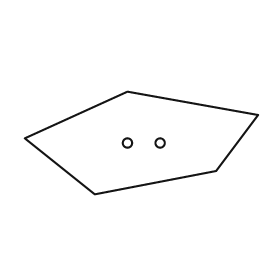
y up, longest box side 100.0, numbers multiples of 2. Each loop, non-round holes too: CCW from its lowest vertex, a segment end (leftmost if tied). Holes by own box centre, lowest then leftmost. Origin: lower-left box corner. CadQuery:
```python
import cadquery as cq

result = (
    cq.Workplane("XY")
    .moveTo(30.0, 0.0)
    .lineTo(82.0, 10.0)
    .lineTo(100.0, 34.0)
    .lineTo(44.0, 44.0)
    .lineTo(0.0, 24.0)
    .close()
    .moveTo(44.0, 22.0)
    .circle(2.0)
    .moveTo(58.0, 22.0)
    .circle(2.0)
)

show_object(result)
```